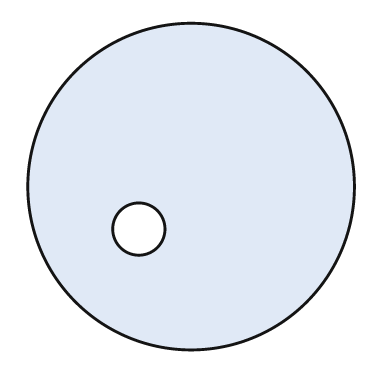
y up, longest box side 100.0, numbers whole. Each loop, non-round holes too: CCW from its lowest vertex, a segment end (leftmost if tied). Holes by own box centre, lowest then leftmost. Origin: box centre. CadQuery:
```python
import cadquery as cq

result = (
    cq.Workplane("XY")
    .moveTo(0.0, 0.0)
    .circle(50.0)
    .moveTo(-16.0, -13.0)
    .circle(8.0)
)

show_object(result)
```